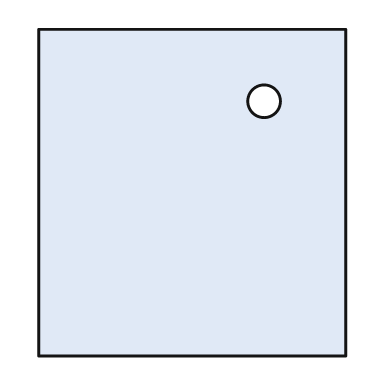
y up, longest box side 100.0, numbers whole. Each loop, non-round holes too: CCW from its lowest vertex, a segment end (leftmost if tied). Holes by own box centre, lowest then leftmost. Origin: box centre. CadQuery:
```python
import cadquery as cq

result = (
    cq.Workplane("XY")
    .moveTo(-47.0, -50.0)
    .lineTo(47.0, -50.0)
    .lineTo(47.0, 50.0)
    .lineTo(-47.0, 50.0)
    .close()
    .moveTo(22.0, 28.0)
    .circle(5.0)
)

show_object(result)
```